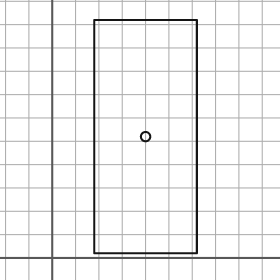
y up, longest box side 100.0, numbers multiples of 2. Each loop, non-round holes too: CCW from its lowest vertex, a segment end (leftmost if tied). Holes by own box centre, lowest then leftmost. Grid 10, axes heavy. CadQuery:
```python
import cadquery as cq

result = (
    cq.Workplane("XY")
    .moveTo(18.0, 2.0)
    .lineTo(62.0, 2.0)
    .lineTo(62.0, 102.0)
    .lineTo(18.0, 102.0)
    .close()
    .moveTo(40.0, 52.0)
    .circle(2.0)
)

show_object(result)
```